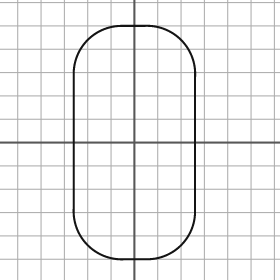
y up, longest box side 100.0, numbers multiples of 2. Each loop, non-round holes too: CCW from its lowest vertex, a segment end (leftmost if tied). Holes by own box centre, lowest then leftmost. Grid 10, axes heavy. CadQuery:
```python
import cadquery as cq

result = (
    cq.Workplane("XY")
    .moveTo(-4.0, -50.0)
    .lineTo(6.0, -50.0)
    .threePointArc((20.0, -44.0), (26.0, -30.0))
    .lineTo(26.0, 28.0)
    .threePointArc((20.0, 44.0), (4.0, 50.0))
    .lineTo(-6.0, 50.0)
    .threePointArc((-20.0, 44.0), (-26.0, 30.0))
    .lineTo(-26.0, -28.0)
    .threePointArc((-20.0, -44.0), (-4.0, -50.0))
    .close()
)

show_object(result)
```